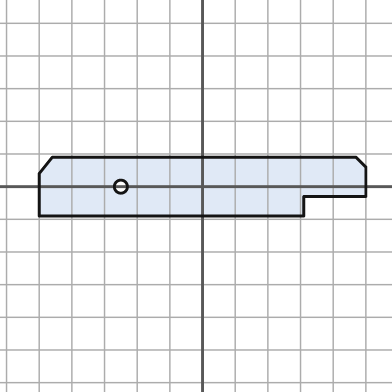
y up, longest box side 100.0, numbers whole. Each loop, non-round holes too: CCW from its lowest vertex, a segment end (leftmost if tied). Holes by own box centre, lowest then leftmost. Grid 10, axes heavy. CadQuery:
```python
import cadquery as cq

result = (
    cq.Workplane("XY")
    .moveTo(-50.0, -9.0)
    .lineTo(31.0, -9.0)
    .lineTo(31.0, -3.0)
    .lineTo(50.0, -3.0)
    .lineTo(50.0, 6.0)
    .lineTo(47.0, 9.0)
    .lineTo(-46.0, 9.0)
    .lineTo(-50.0, 4.0)
    .close()
    .moveTo(-25.0, 0.0)
    .circle(2.0)
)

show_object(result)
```